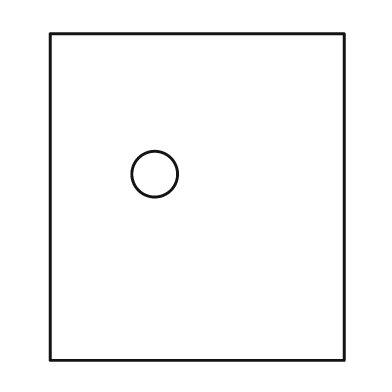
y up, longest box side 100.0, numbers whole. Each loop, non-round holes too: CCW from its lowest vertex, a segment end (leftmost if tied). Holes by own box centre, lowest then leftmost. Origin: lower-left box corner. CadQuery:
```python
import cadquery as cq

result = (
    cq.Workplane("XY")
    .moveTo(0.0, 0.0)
    .lineTo(90.0, 0.0)
    .lineTo(90.0, 100.0)
    .lineTo(0.0, 100.0)
    .close()
    .moveTo(32.0, 57.0)
    .circle(7.0)
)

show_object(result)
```